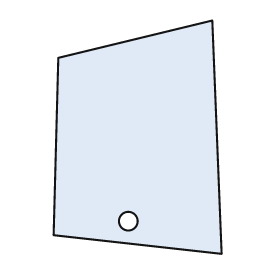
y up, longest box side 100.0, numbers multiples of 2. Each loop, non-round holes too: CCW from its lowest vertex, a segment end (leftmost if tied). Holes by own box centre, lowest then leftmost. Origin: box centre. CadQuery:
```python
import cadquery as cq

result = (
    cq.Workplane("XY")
    .moveTo(36.0, -50.0)
    .lineTo(32.0, 50.0)
    .lineTo(-34.0, 34.0)
    .lineTo(-36.0, -42.0)
    .close()
    .moveTo(-4.0, -36.0)
    .circle(4.0)
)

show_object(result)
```